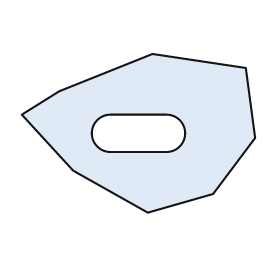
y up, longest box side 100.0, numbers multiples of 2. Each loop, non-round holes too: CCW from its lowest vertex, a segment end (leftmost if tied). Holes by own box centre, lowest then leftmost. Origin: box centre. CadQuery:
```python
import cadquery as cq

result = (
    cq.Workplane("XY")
    .moveTo(4.0, -34.0)
    .lineTo(32.0, -26.0)
    .lineTo(50.0, -2.0)
    .lineTo(46.0, 28.0)
    .lineTo(6.0, 34.0)
    .lineTo(-34.0, 18.0)
    .lineTo(-50.0, 8.0)
    .lineTo(-28.0, -16.0)
    .close()
    .moveTo(-12.0, -8.0)
    .lineTo(12.0, -8.0)
    .threePointArc((20.0, 0.0), (12.0, 8.0))
    .lineTo(-12.0, 8.0)
    .threePointArc((-20.0, 0.0), (-12.0, -8.0))
    .close()
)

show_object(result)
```